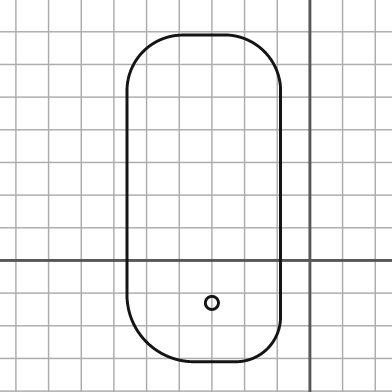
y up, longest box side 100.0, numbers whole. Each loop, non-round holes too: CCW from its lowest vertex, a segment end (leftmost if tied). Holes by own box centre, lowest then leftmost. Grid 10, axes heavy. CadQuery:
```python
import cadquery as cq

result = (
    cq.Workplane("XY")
    .moveTo(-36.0, -31.0)
    .lineTo(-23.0, -31.0)
    .threePointArc((-13.0, -27.0), (-9.0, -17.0))
    .lineTo(-9.0, 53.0)
    .threePointArc((-14.0, 64.0), (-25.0, 69.0))
    .lineTo(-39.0, 69.0)
    .threePointArc((-51.0, 64.0), (-56.0, 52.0))
    .lineTo(-56.0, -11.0)
    .threePointArc((-50.0, -25.0), (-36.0, -31.0))
    .close()
    .moveTo(-30.0, -13.0)
    .circle(2.0)
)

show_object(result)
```